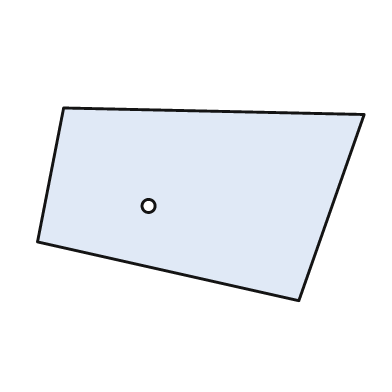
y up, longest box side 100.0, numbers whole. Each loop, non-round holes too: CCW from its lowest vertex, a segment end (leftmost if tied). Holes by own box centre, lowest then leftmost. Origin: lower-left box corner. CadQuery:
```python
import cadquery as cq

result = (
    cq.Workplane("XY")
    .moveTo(80.0, 0.0)
    .lineTo(100.0, 57.0)
    .lineTo(8.0, 59.0)
    .lineTo(0.0, 18.0)
    .close()
    .moveTo(34.0, 29.0)
    .circle(2.0)
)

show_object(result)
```